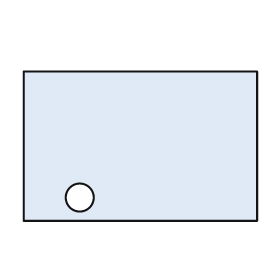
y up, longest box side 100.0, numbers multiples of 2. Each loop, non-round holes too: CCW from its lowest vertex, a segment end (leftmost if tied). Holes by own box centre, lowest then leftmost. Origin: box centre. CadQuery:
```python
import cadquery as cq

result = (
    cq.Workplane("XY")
    .moveTo(-50.0, -32.0)
    .lineTo(50.0, -32.0)
    .lineTo(50.0, 32.0)
    .lineTo(-50.0, 32.0)
    .close()
    .moveTo(-26.0, -22.0)
    .circle(6.0)
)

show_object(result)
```